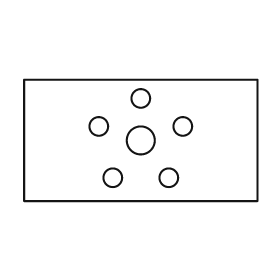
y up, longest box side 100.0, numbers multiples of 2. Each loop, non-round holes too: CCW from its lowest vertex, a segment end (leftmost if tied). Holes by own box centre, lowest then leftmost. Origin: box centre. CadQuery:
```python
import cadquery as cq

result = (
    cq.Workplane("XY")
    .moveTo(-50.0, -26.0)
    .lineTo(50.0, -26.0)
    .lineTo(50.0, 26.0)
    .lineTo(-50.0, 26.0)
    .close()
    .moveTo(-12.0, -16.0)
    .circle(4.0)
    .moveTo(12.0, -16.0)
    .circle(4.0)
    .moveTo(0.0, 0.0)
    .circle(6.0)
    .moveTo(-18.0, 6.0)
    .circle(4.0)
    .moveTo(18.0, 6.0)
    .circle(4.0)
    .moveTo(0.0, 18.0)
    .circle(4.0)
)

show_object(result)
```